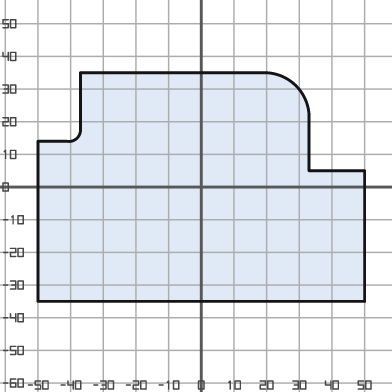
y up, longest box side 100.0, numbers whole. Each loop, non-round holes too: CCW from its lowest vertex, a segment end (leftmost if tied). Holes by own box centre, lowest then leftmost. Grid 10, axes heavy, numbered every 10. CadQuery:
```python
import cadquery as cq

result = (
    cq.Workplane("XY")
    .moveTo(-50.0, -35.0)
    .lineTo(50.0, -35.0)
    .lineTo(50.0, 5.0)
    .lineTo(33.0, 5.0)
    .lineTo(33.0, 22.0)
    .threePointArc((29.0, 31.0), (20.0, 35.0))
    .lineTo(-37.0, 35.0)
    .lineTo(-37.0, 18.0)
    .threePointArc((-38.0, 15.0), (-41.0, 14.0))
    .lineTo(-50.0, 14.0)
    .close()
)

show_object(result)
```